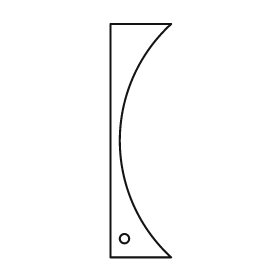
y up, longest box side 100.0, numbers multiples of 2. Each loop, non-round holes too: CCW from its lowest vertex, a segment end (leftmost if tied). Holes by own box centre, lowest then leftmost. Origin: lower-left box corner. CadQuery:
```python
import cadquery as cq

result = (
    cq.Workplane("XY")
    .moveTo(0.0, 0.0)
    .lineTo(26.0, 0.0)
    .threePointArc((4.0, 50.0), (26.0, 100.0))
    .lineTo(0.0, 100.0)
    .close()
    .moveTo(6.0, 8.0)
    .circle(2.0)
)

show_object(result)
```